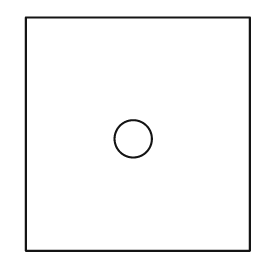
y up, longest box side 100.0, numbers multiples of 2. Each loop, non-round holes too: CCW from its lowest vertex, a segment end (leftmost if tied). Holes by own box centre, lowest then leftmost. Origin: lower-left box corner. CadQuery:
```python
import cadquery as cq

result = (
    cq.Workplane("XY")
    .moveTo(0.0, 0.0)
    .lineTo(96.0, 0.0)
    .lineTo(96.0, 100.0)
    .lineTo(0.0, 100.0)
    .close()
    .moveTo(46.0, 48.0)
    .circle(8.0)
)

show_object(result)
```